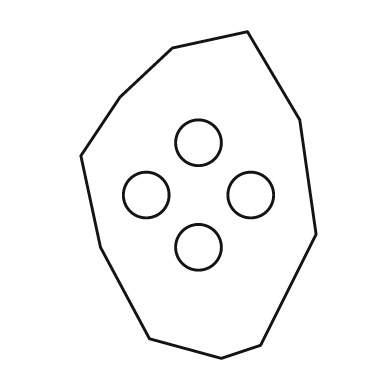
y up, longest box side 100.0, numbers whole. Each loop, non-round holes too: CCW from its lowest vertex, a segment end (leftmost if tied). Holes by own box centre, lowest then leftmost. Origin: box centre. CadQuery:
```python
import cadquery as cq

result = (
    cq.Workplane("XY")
    .moveTo(7.0, -50.0)
    .lineTo(19.0, -46.0)
    .lineTo(36.0, -12.0)
    .lineTo(31.0, 23.0)
    .lineTo(15.0, 50.0)
    .lineTo(-8.0, 45.0)
    .lineTo(-24.0, 30.0)
    .lineTo(-36.0, 12.0)
    .lineTo(-30.0, -16.0)
    .lineTo(-15.0, -44.0)
    .close()
    .moveTo(0.0, -16.0)
    .circle(7.0)
    .moveTo(-16.0, 0.0)
    .circle(7.0)
    .moveTo(16.0, 0.0)
    .circle(7.0)
    .moveTo(0.0, 16.0)
    .circle(7.0)
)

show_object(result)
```